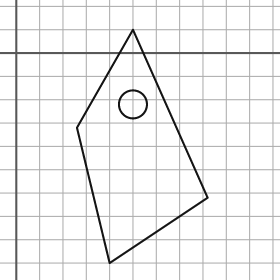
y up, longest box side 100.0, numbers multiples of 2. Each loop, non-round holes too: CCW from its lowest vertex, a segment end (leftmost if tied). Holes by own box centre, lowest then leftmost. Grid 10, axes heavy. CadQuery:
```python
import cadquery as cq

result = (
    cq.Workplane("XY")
    .moveTo(40.0, -90.0)
    .lineTo(82.0, -62.0)
    .lineTo(50.0, 10.0)
    .lineTo(26.0, -32.0)
    .close()
    .moveTo(50.0, -22.0)
    .circle(6.0)
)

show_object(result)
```